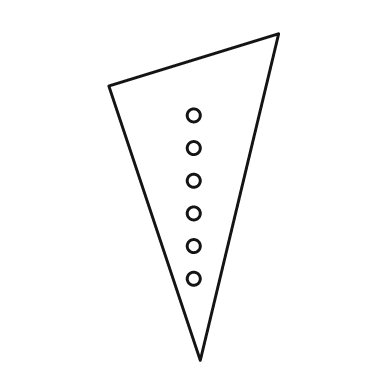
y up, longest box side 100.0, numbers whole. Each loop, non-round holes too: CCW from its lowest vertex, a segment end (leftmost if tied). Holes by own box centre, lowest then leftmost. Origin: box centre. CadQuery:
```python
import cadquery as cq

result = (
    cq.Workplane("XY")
    .moveTo(2.0, -50.0)
    .lineTo(26.0, 50.0)
    .lineTo(-26.0, 34.0)
    .close()
    .moveTo(0.0, -25.0)
    .circle(2.0)
    .moveTo(0.0, -15.0)
    .circle(2.0)
    .moveTo(0.0, -5.0)
    .circle(2.0)
    .moveTo(0.0, 5.0)
    .circle(2.0)
    .moveTo(0.0, 15.0)
    .circle(2.0)
    .moveTo(0.0, 25.0)
    .circle(2.0)
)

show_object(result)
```